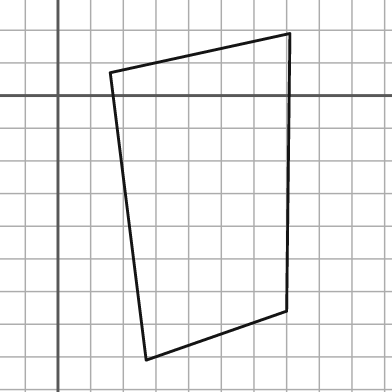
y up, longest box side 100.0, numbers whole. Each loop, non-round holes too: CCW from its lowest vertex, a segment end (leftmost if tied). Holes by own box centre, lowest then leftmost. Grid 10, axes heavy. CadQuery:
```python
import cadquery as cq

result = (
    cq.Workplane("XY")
    .moveTo(27.0, -81.0)
    .lineTo(70.0, -66.0)
    .lineTo(71.0, 19.0)
    .lineTo(16.0, 7.0)
    .close()
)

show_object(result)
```